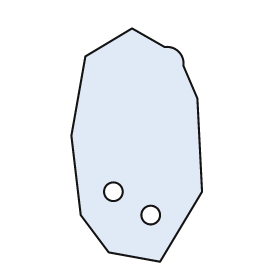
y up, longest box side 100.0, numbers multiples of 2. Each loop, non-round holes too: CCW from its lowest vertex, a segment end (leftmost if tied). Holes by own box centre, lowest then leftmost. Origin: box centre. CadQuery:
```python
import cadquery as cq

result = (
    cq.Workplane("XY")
    .moveTo(10.0, -50.0)
    .lineTo(28.0, -20.0)
    .lineTo(26.0, 20.0)
    .lineTo(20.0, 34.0)
    .threePointArc((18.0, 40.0), (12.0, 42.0))
    .lineTo(-2.0, 50.0)
    .lineTo(-22.0, 38.0)
    .lineTo(-28.0, 4.0)
    .lineTo(-24.0, -30.0)
    .lineTo(-12.0, -46.0)
    .close()
    .moveTo(6.0, -30.0)
    .circle(4.0)
    .moveTo(-10.0, -20.0)
    .circle(4.0)
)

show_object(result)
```